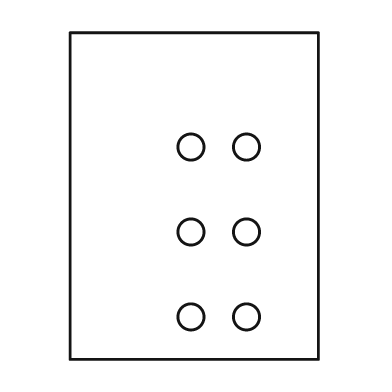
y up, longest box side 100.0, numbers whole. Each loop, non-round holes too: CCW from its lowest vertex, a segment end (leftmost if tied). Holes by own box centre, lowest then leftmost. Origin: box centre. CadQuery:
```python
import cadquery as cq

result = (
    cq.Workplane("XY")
    .moveTo(-38.0, -50.0)
    .lineTo(38.0, -50.0)
    .lineTo(38.0, 50.0)
    .lineTo(-38.0, 50.0)
    .close()
    .moveTo(-1.0, -37.0)
    .circle(4.0)
    .moveTo(16.0, -37.0)
    .circle(4.0)
    .moveTo(-1.0, -11.0)
    .circle(4.0)
    .moveTo(16.0, -11.0)
    .circle(4.0)
    .moveTo(-1.0, 15.0)
    .circle(4.0)
    .moveTo(16.0, 15.0)
    .circle(4.0)
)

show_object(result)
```